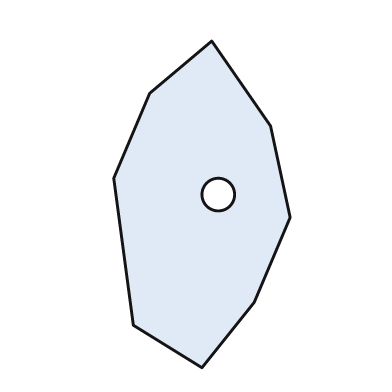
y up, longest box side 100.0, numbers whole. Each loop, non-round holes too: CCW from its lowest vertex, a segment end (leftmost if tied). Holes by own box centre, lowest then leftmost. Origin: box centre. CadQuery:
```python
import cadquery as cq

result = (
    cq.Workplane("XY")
    .moveTo(0.0, -50.0)
    .lineTo(16.0, -30.0)
    .lineTo(27.0, -4.0)
    .lineTo(21.0, 24.0)
    .lineTo(3.0, 50.0)
    .lineTo(-16.0, 34.0)
    .lineTo(-27.0, 8.0)
    .lineTo(-21.0, -37.0)
    .close()
    .moveTo(5.0, 3.0)
    .circle(5.0)
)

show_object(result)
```